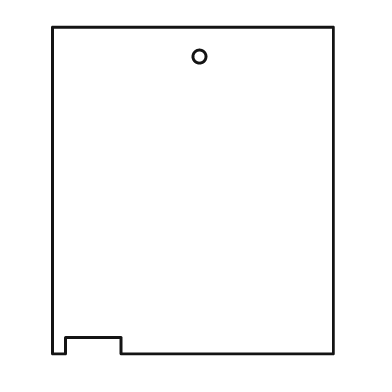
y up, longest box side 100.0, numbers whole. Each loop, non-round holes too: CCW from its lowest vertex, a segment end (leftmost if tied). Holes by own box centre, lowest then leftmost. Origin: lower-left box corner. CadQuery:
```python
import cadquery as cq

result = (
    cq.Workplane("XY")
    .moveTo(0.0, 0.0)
    .lineTo(4.0, 0.0)
    .lineTo(4.0, 5.0)
    .lineTo(21.0, 5.0)
    .lineTo(21.0, 0.0)
    .lineTo(86.0, 0.0)
    .lineTo(86.0, 100.0)
    .lineTo(0.0, 100.0)
    .close()
    .moveTo(45.0, 91.0)
    .circle(2.0)
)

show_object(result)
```